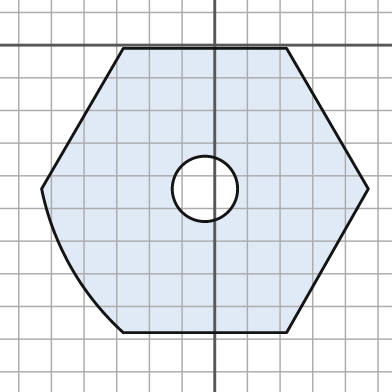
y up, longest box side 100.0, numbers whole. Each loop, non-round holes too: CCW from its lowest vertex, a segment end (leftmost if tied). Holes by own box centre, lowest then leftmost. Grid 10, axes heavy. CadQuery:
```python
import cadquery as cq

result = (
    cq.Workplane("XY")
    .moveTo(-28.0, -88.0)
    .lineTo(22.0, -88.0)
    .lineTo(47.0, -44.0)
    .lineTo(22.0, -1.0)
    .lineTo(-28.0, -1.0)
    .lineTo(-53.0, -44.0)
    .threePointArc((-44.0, -68.0), (-28.0, -88.0))
    .close()
    .moveTo(-3.0, -44.0)
    .circle(10.0)
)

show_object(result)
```